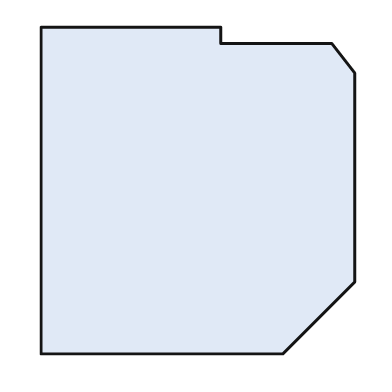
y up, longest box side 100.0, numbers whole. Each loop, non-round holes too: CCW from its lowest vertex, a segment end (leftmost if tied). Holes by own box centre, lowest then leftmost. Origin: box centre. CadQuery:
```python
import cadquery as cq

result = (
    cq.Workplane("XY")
    .moveTo(-48.0, -50.0)
    .lineTo(26.0, -50.0)
    .lineTo(48.0, -28.0)
    .lineTo(48.0, 36.0)
    .lineTo(41.0, 45.0)
    .lineTo(7.0, 45.0)
    .lineTo(7.0, 50.0)
    .lineTo(-48.0, 50.0)
    .close()
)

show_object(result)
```